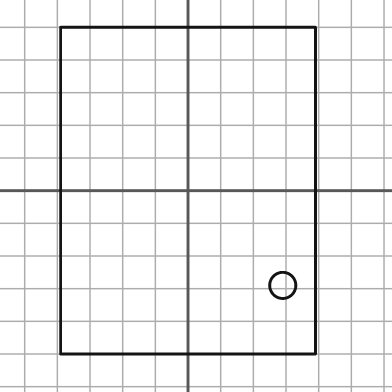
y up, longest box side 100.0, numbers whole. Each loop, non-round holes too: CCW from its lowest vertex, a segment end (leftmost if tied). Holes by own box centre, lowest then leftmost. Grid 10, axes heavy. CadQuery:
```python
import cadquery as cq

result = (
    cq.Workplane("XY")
    .moveTo(-39.0, -50.0)
    .lineTo(39.0, -50.0)
    .lineTo(39.0, 50.0)
    .lineTo(-39.0, 50.0)
    .close()
    .moveTo(29.0, -29.0)
    .circle(4.0)
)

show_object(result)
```